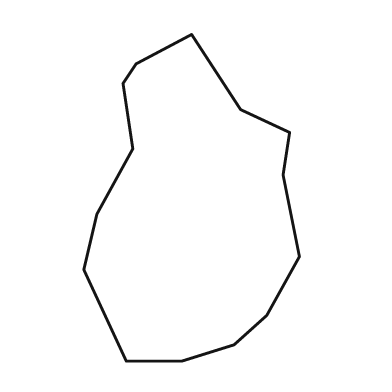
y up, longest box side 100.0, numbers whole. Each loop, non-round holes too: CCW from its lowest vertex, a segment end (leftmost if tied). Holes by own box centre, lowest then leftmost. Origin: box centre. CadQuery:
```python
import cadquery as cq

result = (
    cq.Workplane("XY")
    .moveTo(-20.0, -50.0)
    .lineTo(-3.0, -50.0)
    .lineTo(13.0, -45.0)
    .lineTo(23.0, -36.0)
    .lineTo(33.0, -18.0)
    .lineTo(28.0, 7.0)
    .lineTo(30.0, 20.0)
    .lineTo(15.0, 27.0)
    .lineTo(0.0, 50.0)
    .lineTo(-17.0, 41.0)
    .lineTo(-21.0, 35.0)
    .lineTo(-18.0, 15.0)
    .lineTo(-29.0, -5.0)
    .lineTo(-33.0, -22.0)
    .close()
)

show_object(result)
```